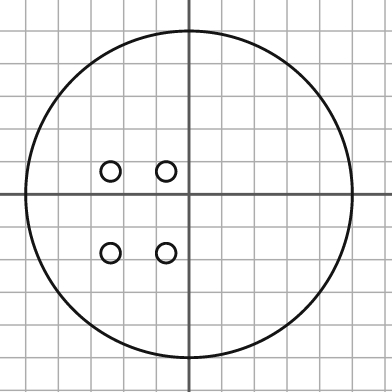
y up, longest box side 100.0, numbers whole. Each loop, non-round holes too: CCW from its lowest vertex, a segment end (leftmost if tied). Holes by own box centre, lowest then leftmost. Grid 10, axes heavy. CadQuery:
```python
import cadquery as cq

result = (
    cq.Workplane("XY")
    .moveTo(0.0, 0.0)
    .circle(50.0)
    .moveTo(-24.0, -18.0)
    .circle(3.0)
    .moveTo(-7.0, -18.0)
    .circle(3.0)
    .moveTo(-24.0, 7.0)
    .circle(3.0)
    .moveTo(-7.0, 7.0)
    .circle(3.0)
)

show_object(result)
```